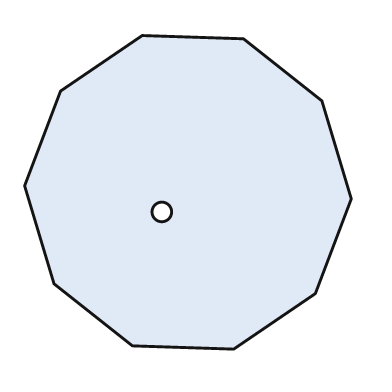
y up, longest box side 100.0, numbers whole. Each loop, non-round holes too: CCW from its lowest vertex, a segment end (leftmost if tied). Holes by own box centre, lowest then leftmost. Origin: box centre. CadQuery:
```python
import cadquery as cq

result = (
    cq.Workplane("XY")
    .moveTo(14.0, -48.0)
    .lineTo(39.0, -31.0)
    .lineTo(50.0, -2.0)
    .lineTo(41.0, 28.0)
    .lineTo(17.0, 47.0)
    .lineTo(-14.0, 48.0)
    .lineTo(-39.0, 31.0)
    .lineTo(-50.0, 2.0)
    .lineTo(-41.0, -28.0)
    .lineTo(-17.0, -47.0)
    .close()
    .moveTo(-8.0, -6.0)
    .circle(3.0)
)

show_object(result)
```